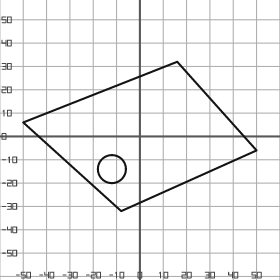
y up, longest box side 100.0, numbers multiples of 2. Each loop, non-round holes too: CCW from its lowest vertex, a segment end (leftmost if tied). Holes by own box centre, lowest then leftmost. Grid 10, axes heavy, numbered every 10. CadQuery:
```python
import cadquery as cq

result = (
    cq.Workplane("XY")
    .moveTo(-8.0, -32.0)
    .lineTo(50.0, -6.0)
    .lineTo(16.0, 32.0)
    .lineTo(-50.0, 6.0)
    .close()
    .moveTo(-12.0, -14.0)
    .circle(6.0)
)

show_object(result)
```